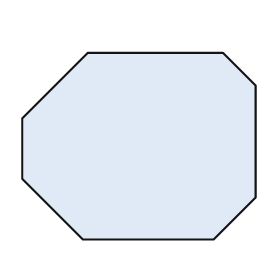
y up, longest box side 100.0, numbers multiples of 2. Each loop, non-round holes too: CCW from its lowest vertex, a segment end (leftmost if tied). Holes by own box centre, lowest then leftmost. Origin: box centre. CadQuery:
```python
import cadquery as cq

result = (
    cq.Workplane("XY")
    .moveTo(-24.0, -40.0)
    .lineTo(32.0, -40.0)
    .lineTo(50.0, -22.0)
    .lineTo(50.0, 26.0)
    .lineTo(36.0, 40.0)
    .lineTo(-22.0, 40.0)
    .lineTo(-50.0, 12.0)
    .lineTo(-50.0, -14.0)
    .close()
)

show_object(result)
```